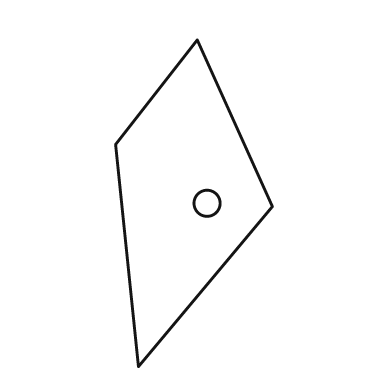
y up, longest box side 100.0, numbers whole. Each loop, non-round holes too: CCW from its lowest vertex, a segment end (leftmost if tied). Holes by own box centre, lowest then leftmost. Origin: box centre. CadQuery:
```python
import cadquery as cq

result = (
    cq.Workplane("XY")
    .moveTo(-17.0, -50.0)
    .lineTo(24.0, -1.0)
    .lineTo(1.0, 50.0)
    .lineTo(-24.0, 18.0)
    .close()
    .moveTo(4.0, 0.0)
    .circle(4.0)
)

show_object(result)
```